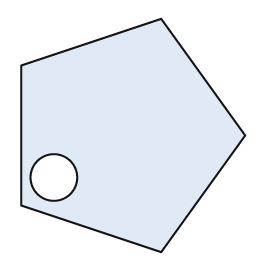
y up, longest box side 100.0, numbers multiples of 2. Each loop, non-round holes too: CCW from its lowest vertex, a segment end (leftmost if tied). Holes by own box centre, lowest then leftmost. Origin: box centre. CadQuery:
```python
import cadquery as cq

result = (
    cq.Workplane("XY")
    .moveTo(12.0, -50.0)
    .lineTo(48.0, 0.0)
    .lineTo(12.0, 50.0)
    .lineTo(-48.0, 30.0)
    .lineTo(-48.0, -30.0)
    .close()
    .moveTo(-34.0, -18.0)
    .circle(10.0)
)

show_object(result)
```